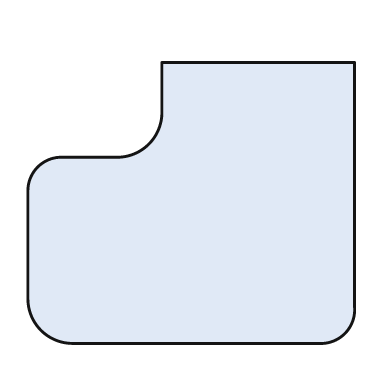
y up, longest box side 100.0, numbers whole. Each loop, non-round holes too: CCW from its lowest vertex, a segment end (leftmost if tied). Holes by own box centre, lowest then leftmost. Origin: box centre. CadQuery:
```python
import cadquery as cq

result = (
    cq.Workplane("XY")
    .moveTo(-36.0, -43.0)
    .lineTo(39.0, -43.0)
    .threePointArc((47.0, -40.0), (50.0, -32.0))
    .lineTo(50.0, 43.0)
    .lineTo(-9.0, 43.0)
    .lineTo(-9.0, 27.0)
    .threePointArc((-13.0, 18.0), (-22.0, 14.0))
    .lineTo(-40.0, 14.0)
    .threePointArc((-47.0, 11.0), (-50.0, 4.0))
    .lineTo(-50.0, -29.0)
    .threePointArc((-46.0, -39.0), (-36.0, -43.0))
    .close()
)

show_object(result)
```